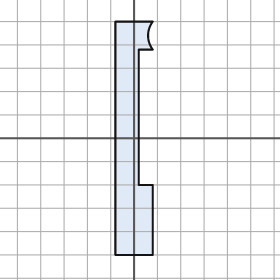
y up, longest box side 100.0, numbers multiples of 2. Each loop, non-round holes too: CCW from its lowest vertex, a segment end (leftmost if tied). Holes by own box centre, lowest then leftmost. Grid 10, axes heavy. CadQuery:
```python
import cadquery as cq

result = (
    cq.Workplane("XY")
    .moveTo(-8.0, -50.0)
    .lineTo(8.0, -50.0)
    .lineTo(8.0, -20.0)
    .lineTo(2.0, -20.0)
    .lineTo(2.0, 38.0)
    .lineTo(8.0, 38.0)
    .threePointArc((6.0, 44.0), (8.0, 50.0))
    .lineTo(-8.0, 50.0)
    .close()
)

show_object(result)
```